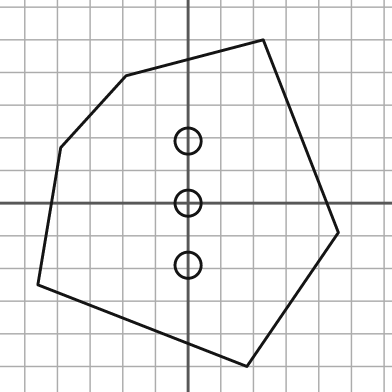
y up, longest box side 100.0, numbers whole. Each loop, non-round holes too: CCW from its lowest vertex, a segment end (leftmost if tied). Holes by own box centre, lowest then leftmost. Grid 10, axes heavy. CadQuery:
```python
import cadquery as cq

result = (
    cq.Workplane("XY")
    .moveTo(18.0, -50.0)
    .lineTo(46.0, -9.0)
    .lineTo(23.0, 50.0)
    .lineTo(-19.0, 39.0)
    .lineTo(-39.0, 17.0)
    .lineTo(-46.0, -25.0)
    .close()
    .moveTo(0.0, -19.0)
    .circle(4.0)
    .moveTo(0.0, 0.0)
    .circle(4.0)
    .moveTo(0.0, 19.0)
    .circle(4.0)
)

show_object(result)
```